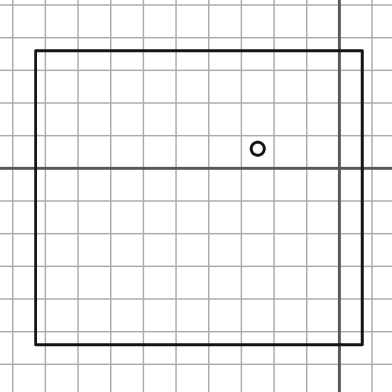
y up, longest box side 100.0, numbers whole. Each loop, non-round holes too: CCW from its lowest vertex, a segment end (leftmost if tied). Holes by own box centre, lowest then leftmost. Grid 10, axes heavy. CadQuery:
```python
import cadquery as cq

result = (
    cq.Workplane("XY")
    .moveTo(-93.0, -54.0)
    .lineTo(7.0, -54.0)
    .lineTo(7.0, 36.0)
    .lineTo(-93.0, 36.0)
    .close()
    .moveTo(-25.0, 6.0)
    .circle(2.0)
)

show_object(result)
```